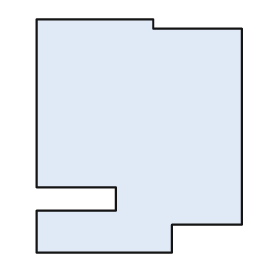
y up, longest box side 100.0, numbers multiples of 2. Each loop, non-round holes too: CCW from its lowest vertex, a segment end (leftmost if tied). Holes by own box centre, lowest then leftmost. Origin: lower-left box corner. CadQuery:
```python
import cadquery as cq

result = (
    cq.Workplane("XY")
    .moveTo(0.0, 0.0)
    .lineTo(58.0, 0.0)
    .lineTo(58.0, 12.0)
    .lineTo(88.0, 12.0)
    .lineTo(88.0, 96.0)
    .lineTo(50.0, 96.0)
    .lineTo(50.0, 100.0)
    .lineTo(0.0, 100.0)
    .lineTo(0.0, 28.0)
    .lineTo(34.0, 28.0)
    .lineTo(34.0, 18.0)
    .lineTo(0.0, 18.0)
    .close()
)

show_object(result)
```